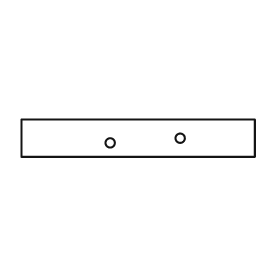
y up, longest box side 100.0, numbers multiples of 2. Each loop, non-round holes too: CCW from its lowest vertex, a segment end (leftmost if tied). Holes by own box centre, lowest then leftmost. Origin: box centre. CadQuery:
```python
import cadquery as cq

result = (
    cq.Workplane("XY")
    .moveTo(-50.0, -8.0)
    .lineTo(50.0, -8.0)
    .lineTo(50.0, 8.0)
    .lineTo(-50.0, 8.0)
    .close()
    .moveTo(-12.0, -2.0)
    .circle(2.0)
    .moveTo(18.0, 0.0)
    .circle(2.0)
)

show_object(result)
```